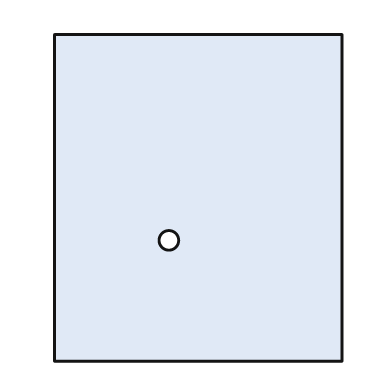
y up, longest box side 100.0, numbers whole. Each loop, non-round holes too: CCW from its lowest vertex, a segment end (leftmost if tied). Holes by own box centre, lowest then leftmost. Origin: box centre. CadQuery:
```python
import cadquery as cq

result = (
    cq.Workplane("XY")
    .moveTo(-44.0, -50.0)
    .lineTo(44.0, -50.0)
    .lineTo(44.0, 50.0)
    .lineTo(-44.0, 50.0)
    .close()
    .moveTo(-9.0, -13.0)
    .circle(3.0)
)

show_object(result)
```